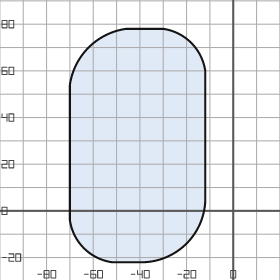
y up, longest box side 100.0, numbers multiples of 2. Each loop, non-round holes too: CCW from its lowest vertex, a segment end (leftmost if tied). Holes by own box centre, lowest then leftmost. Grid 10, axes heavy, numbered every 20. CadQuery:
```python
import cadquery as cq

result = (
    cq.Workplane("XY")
    .moveTo(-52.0, -22.0)
    .lineTo(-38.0, -22.0)
    .threePointArc((-20.0, -14.0), (-12.0, 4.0))
    .lineTo(-12.0, 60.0)
    .threePointArc((-18.0, 72.0), (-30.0, 78.0))
    .lineTo(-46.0, 78.0)
    .threePointArc((-62.0, 70.0), (-70.0, 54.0))
    .lineTo(-70.0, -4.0)
    .threePointArc((-64.0, -16.0), (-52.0, -22.0))
    .close()
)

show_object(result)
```